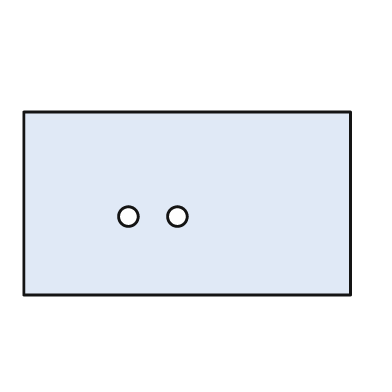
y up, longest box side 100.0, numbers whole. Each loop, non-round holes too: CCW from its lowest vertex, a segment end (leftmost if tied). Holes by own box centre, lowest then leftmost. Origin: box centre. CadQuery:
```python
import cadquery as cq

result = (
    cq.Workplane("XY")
    .moveTo(-50.0, -28.0)
    .lineTo(50.0, -28.0)
    .lineTo(50.0, 28.0)
    .lineTo(-50.0, 28.0)
    .close()
    .moveTo(-18.0, -4.0)
    .circle(3.0)
    .moveTo(-3.0, -4.0)
    .circle(3.0)
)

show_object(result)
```